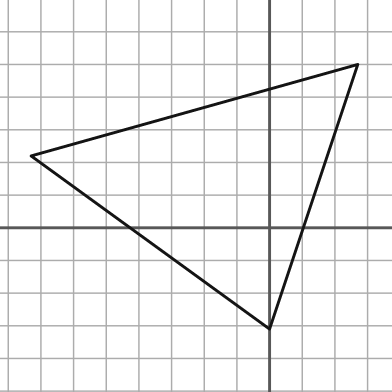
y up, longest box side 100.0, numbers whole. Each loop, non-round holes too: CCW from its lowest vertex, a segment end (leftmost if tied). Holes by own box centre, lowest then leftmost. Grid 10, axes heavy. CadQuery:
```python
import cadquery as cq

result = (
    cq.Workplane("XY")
    .moveTo(0.0, -31.0)
    .lineTo(27.0, 50.0)
    .lineTo(-73.0, 22.0)
    .close()
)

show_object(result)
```